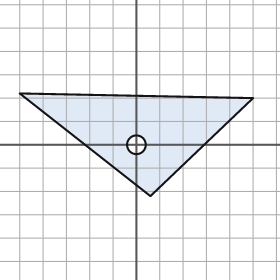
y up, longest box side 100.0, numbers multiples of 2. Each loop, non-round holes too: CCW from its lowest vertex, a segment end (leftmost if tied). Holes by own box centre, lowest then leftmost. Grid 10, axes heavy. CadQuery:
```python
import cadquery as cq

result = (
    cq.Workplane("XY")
    .moveTo(6.0, -22.0)
    .lineTo(50.0, 20.0)
    .lineTo(-50.0, 22.0)
    .close()
    .moveTo(0.0, 0.0)
    .circle(4.0)
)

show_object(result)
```